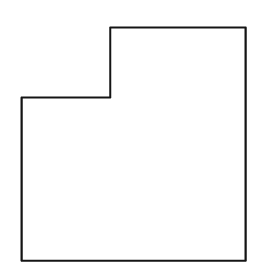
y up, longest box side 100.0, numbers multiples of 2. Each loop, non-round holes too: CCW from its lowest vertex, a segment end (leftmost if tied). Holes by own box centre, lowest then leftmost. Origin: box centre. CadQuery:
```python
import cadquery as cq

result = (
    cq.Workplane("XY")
    .moveTo(-48.0, -50.0)
    .lineTo(48.0, -50.0)
    .lineTo(48.0, 50.0)
    .lineTo(-10.0, 50.0)
    .lineTo(-10.0, 20.0)
    .lineTo(-48.0, 20.0)
    .close()
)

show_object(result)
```